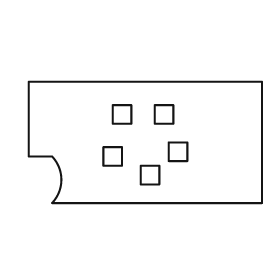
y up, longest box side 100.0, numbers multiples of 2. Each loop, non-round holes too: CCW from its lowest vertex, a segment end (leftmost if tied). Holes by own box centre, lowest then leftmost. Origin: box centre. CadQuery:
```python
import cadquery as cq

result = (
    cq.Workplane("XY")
    .moveTo(-40.0, -26.0)
    .lineTo(50.0, -26.0)
    .lineTo(50.0, 26.0)
    .lineTo(-50.0, 26.0)
    .lineTo(-50.0, -6.0)
    .lineTo(-40.0, -6.0)
    .threePointArc((-36.0, -16.0), (-40.0, -26.0))
    .close()
    .moveTo(-2.0, -18.0)
    .lineTo(6.0, -18.0)
    .lineTo(6.0, -10.0)
    .lineTo(-2.0, -10.0)
    .close()
    .moveTo(-18.0, -10.0)
    .lineTo(-10.0, -10.0)
    .lineTo(-10.0, -2.0)
    .lineTo(-18.0, -2.0)
    .close()
    .moveTo(10.0, -8.0)
    .lineTo(18.0, -8.0)
    .lineTo(18.0, 0.0)
    .lineTo(10.0, 0.0)
    .close()
    .moveTo(-14.0, 8.0)
    .lineTo(-6.0, 8.0)
    .lineTo(-6.0, 16.0)
    .lineTo(-14.0, 16.0)
    .close()
    .moveTo(4.0, 8.0)
    .lineTo(12.0, 8.0)
    .lineTo(12.0, 16.0)
    .lineTo(4.0, 16.0)
    .close()
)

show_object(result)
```